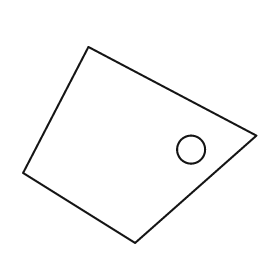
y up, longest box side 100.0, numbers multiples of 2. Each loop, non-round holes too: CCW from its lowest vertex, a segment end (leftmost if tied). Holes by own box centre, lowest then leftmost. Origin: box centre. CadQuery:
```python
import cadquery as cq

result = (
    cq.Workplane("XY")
    .moveTo(-2.0, -42.0)
    .lineTo(50.0, 4.0)
    .lineTo(-22.0, 42.0)
    .lineTo(-50.0, -12.0)
    .close()
    .moveTo(22.0, -2.0)
    .circle(6.0)
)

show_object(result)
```